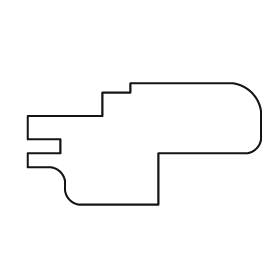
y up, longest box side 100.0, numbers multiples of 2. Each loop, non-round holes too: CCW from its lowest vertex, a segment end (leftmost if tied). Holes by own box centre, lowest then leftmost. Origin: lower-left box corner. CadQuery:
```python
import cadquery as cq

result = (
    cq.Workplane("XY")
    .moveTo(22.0, 0.0)
    .lineTo(56.0, 0.0)
    .lineTo(56.0, 22.0)
    .lineTo(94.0, 22.0)
    .threePointArc((98.0, 24.0), (100.0, 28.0))
    .lineTo(100.0, 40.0)
    .threePointArc((96.0, 48.0), (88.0, 52.0))
    .lineTo(44.0, 52.0)
    .lineTo(44.0, 48.0)
    .lineTo(32.0, 48.0)
    .lineTo(32.0, 38.0)
    .lineTo(0.0, 38.0)
    .lineTo(0.0, 28.0)
    .lineTo(14.0, 28.0)
    .lineTo(14.0, 22.0)
    .lineTo(0.0, 22.0)
    .lineTo(0.0, 16.0)
    .lineTo(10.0, 16.0)
    .threePointArc((14.0, 14.0), (16.0, 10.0))
    .lineTo(16.0, 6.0)
    .threePointArc((18.0, 2.0), (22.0, 0.0))
    .close()
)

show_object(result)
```